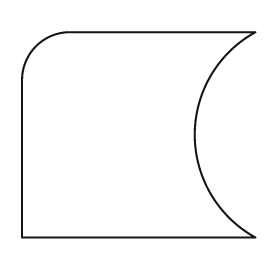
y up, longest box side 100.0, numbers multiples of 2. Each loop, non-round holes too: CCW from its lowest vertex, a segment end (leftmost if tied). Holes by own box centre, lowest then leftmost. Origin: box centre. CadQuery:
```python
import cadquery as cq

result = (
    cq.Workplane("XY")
    .moveTo(-50.0, -44.0)
    .lineTo(50.0, -44.0)
    .threePointArc((24.0, 0.0), (50.0, 44.0))
    .lineTo(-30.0, 44.0)
    .threePointArc((-44.0, 38.0), (-50.0, 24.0))
    .close()
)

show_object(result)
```